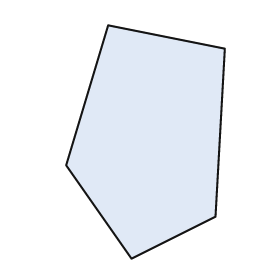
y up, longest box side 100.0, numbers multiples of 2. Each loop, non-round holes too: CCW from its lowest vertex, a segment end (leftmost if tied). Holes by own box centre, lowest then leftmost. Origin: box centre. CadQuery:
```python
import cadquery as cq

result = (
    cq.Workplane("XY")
    .moveTo(-6.0, -50.0)
    .lineTo(30.0, -32.0)
    .lineTo(34.0, 40.0)
    .lineTo(-16.0, 50.0)
    .lineTo(-34.0, -10.0)
    .close()
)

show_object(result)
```